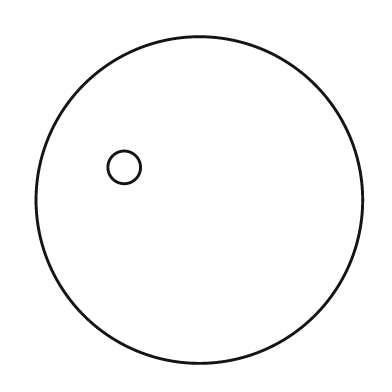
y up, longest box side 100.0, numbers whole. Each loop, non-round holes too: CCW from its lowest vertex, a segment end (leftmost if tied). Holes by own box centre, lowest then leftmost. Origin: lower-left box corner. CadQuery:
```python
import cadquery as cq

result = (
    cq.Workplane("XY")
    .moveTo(50.0, 50.0)
    .circle(50.0)
    .moveTo(27.0, 60.0)
    .circle(5.0)
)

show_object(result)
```